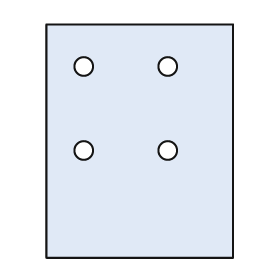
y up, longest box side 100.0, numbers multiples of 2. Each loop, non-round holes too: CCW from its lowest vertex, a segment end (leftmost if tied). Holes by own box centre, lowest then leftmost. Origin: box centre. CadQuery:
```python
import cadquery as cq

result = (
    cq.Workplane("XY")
    .moveTo(-40.0, -50.0)
    .lineTo(40.0, -50.0)
    .lineTo(40.0, 50.0)
    .lineTo(-40.0, 50.0)
    .close()
    .moveTo(-24.0, -4.0)
    .circle(4.0)
    .moveTo(12.0, -4.0)
    .circle(4.0)
    .moveTo(-24.0, 32.0)
    .circle(4.0)
    .moveTo(12.0, 32.0)
    .circle(4.0)
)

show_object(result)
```